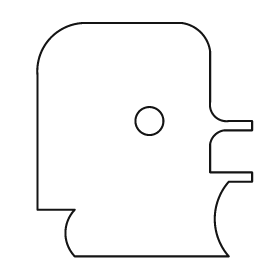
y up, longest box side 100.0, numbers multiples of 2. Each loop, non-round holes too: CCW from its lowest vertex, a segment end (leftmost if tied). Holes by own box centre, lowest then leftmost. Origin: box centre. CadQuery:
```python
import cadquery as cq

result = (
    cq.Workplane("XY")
    .moveTo(-30.0, -50.0)
    .lineTo(36.0, -50.0)
    .threePointArc((30.0, -34.0), (36.0, -18.0))
    .lineTo(46.0, -18.0)
    .lineTo(46.0, -14.0)
    .lineTo(28.0, -14.0)
    .lineTo(28.0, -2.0)
    .threePointArc((30.0, 2.0), (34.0, 4.0))
    .lineTo(46.0, 4.0)
    .lineTo(46.0, 8.0)
    .lineTo(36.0, 8.0)
    .threePointArc((30.0, 10.0), (28.0, 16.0))
    .lineTo(28.0, 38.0)
    .threePointArc((24.0, 46.0), (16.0, 50.0))
    .lineTo(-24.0, 50.0)
    .threePointArc((-40.0, 44.0), (-46.0, 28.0))
    .lineTo(-46.0, -30.0)
    .lineTo(-30.0, -30.0)
    .threePointArc((-34.0, -40.0), (-30.0, -50.0))
    .close()
    .moveTo(2.0, 8.0)
    .circle(6.0)
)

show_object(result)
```